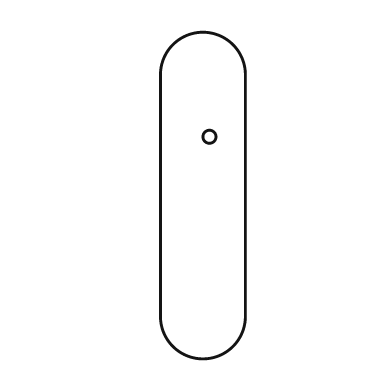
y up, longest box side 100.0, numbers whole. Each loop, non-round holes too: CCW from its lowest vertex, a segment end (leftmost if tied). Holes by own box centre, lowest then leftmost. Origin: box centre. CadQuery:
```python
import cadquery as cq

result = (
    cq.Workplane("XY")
    .moveTo(-13.0, -37.0)
    .threePointArc((0.0, -50.0), (13.0, -37.0))
    .lineTo(13.0, 37.0)
    .threePointArc((0.0, 50.0), (-13.0, 37.0))
    .close()
    .moveTo(2.0, 18.0)
    .circle(2.0)
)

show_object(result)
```